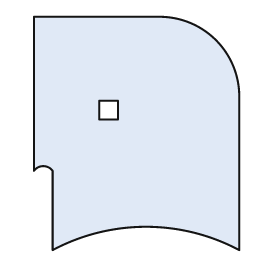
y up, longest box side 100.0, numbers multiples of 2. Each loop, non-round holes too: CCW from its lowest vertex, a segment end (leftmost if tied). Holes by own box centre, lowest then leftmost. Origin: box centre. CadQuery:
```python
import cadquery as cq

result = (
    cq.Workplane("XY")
    .moveTo(-36.0, -50.0)
    .threePointArc((4.0, -40.0), (44.0, -50.0))
    .lineTo(44.0, 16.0)
    .threePointArc((34.0, 40.0), (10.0, 50.0))
    .lineTo(-44.0, 50.0)
    .lineTo(-44.0, -16.0)
    .threePointArc((-40.0, -14.0), (-36.0, -16.0))
    .close()
    .moveTo(-16.0, 6.0)
    .lineTo(-8.0, 6.0)
    .lineTo(-8.0, 14.0)
    .lineTo(-16.0, 14.0)
    .close()
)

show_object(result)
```